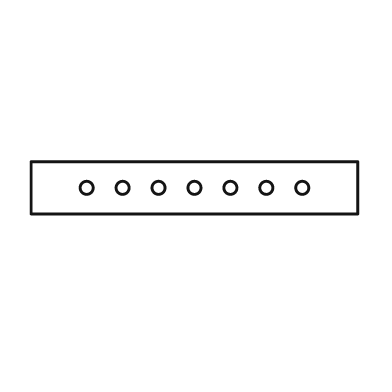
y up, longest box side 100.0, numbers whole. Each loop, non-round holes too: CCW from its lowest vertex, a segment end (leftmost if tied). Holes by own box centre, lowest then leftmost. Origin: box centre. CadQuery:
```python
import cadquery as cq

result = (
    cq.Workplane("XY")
    .moveTo(-50.0, -8.0)
    .lineTo(50.0, -8.0)
    .lineTo(50.0, 8.0)
    .lineTo(-50.0, 8.0)
    .close()
    .moveTo(-33.0, 0.0)
    .circle(2.0)
    .moveTo(-22.0, 0.0)
    .circle(2.0)
    .moveTo(-11.0, 0.0)
    .circle(2.0)
    .moveTo(0.0, 0.0)
    .circle(2.0)
    .moveTo(11.0, 0.0)
    .circle(2.0)
    .moveTo(22.0, 0.0)
    .circle(2.0)
    .moveTo(33.0, 0.0)
    .circle(2.0)
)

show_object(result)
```